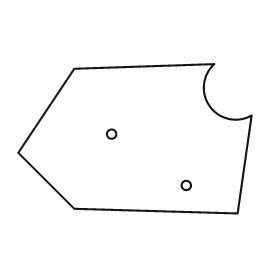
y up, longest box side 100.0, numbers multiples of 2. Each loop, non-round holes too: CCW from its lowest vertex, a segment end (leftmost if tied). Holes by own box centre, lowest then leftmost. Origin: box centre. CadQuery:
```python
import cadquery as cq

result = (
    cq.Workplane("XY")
    .moveTo(44.0, -32.0)
    .lineTo(50.0, 10.0)
    .threePointArc((32.0, 14.0), (34.0, 32.0))
    .lineTo(-26.0, 30.0)
    .lineTo(-50.0, -6.0)
    .lineTo(-26.0, -30.0)
    .close()
    .moveTo(22.0, -20.0)
    .circle(2.0)
    .moveTo(-10.0, 2.0)
    .circle(2.0)
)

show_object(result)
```